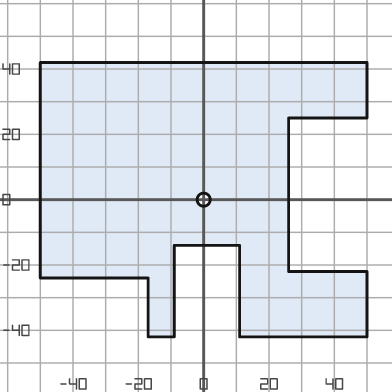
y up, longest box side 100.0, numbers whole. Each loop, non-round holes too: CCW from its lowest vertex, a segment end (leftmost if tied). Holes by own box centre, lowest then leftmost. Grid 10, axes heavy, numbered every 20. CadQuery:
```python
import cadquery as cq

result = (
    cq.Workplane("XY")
    .moveTo(-17.0, -42.0)
    .lineTo(-9.0, -42.0)
    .lineTo(-9.0, -14.0)
    .lineTo(11.0, -14.0)
    .lineTo(11.0, -42.0)
    .lineTo(50.0, -42.0)
    .lineTo(50.0, -22.0)
    .lineTo(26.0, -22.0)
    .lineTo(26.0, 25.0)
    .lineTo(50.0, 25.0)
    .lineTo(50.0, 42.0)
    .lineTo(-50.0, 42.0)
    .lineTo(-50.0, -24.0)
    .lineTo(-17.0, -24.0)
    .close()
    .moveTo(0.0, 0.0)
    .circle(2.0)
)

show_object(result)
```